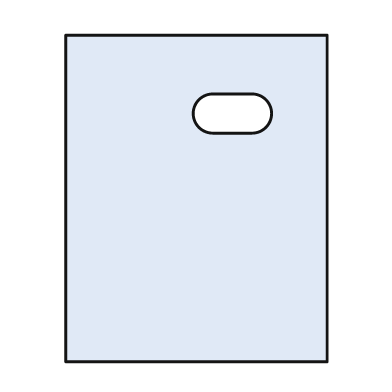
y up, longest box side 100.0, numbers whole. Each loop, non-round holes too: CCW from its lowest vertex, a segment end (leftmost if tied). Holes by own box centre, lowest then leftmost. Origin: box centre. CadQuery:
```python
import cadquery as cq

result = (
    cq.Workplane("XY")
    .moveTo(-40.0, -50.0)
    .lineTo(40.0, -50.0)
    .lineTo(40.0, 50.0)
    .lineTo(-40.0, 50.0)
    .close()
    .moveTo(5.0, 20.0)
    .lineTo(17.0, 20.0)
    .threePointArc((23.0, 26.0), (17.0, 32.0))
    .lineTo(5.0, 32.0)
    .threePointArc((-1.0, 26.0), (5.0, 20.0))
    .close()
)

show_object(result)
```